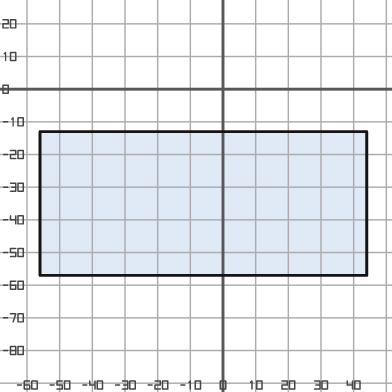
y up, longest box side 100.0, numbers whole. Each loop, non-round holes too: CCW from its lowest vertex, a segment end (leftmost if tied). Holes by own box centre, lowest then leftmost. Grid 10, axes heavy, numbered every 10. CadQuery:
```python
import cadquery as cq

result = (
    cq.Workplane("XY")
    .moveTo(-56.0, -57.0)
    .lineTo(44.0, -57.0)
    .lineTo(44.0, -13.0)
    .lineTo(-56.0, -13.0)
    .close()
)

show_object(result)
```